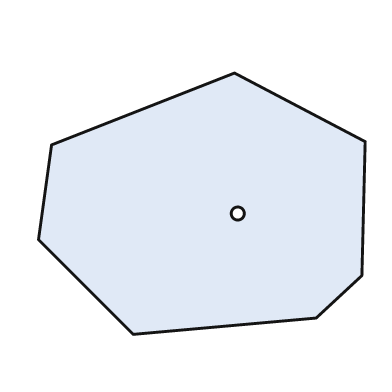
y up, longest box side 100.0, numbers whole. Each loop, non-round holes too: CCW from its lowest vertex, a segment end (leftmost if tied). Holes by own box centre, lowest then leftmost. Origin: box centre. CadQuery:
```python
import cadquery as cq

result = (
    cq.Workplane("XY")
    .moveTo(-21.0, -40.0)
    .lineTo(35.0, -35.0)
    .lineTo(49.0, -22.0)
    .lineTo(50.0, 19.0)
    .lineTo(10.0, 40.0)
    .lineTo(-46.0, 18.0)
    .lineTo(-50.0, -11.0)
    .close()
    .moveTo(11.0, -3.0)
    .circle(2.0)
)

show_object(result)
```